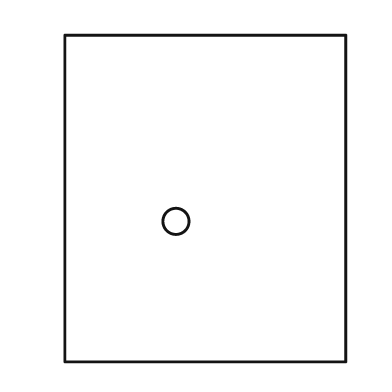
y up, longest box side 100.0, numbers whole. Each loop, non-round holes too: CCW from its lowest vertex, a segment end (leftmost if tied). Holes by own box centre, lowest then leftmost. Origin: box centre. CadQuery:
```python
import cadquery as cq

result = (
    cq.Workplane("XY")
    .moveTo(-43.0, -50.0)
    .lineTo(43.0, -50.0)
    .lineTo(43.0, 50.0)
    .lineTo(-43.0, 50.0)
    .close()
    .moveTo(-9.0, -7.0)
    .circle(4.0)
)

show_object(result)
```